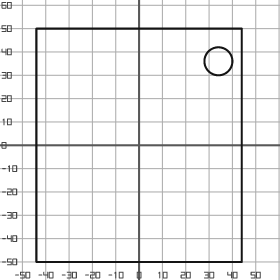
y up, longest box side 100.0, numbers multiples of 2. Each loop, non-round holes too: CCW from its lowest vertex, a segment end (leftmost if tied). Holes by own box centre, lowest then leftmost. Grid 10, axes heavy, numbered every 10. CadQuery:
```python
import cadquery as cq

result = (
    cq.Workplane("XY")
    .moveTo(-44.0, -50.0)
    .lineTo(44.0, -50.0)
    .lineTo(44.0, 50.0)
    .lineTo(-44.0, 50.0)
    .close()
    .moveTo(34.0, 36.0)
    .circle(6.0)
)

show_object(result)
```